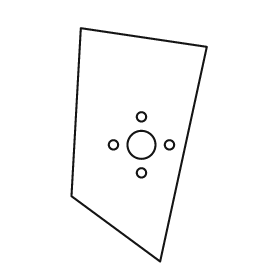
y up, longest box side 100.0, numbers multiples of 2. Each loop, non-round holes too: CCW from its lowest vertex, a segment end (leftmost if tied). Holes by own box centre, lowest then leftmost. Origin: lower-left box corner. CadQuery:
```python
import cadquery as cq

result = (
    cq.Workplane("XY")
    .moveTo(38.0, 0.0)
    .lineTo(58.0, 92.0)
    .lineTo(4.0, 100.0)
    .lineTo(0.0, 28.0)
    .close()
    .moveTo(30.0, 38.0)
    .circle(2.0)
    .moveTo(18.0, 50.0)
    .circle(2.0)
    .moveTo(30.0, 50.0)
    .circle(6.0)
    .moveTo(42.0, 50.0)
    .circle(2.0)
    .moveTo(30.0, 62.0)
    .circle(2.0)
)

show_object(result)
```